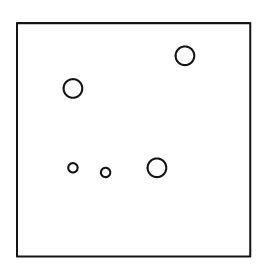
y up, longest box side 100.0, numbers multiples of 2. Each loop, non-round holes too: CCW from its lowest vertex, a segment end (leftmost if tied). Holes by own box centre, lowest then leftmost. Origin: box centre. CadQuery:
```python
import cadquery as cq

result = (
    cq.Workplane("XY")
    .moveTo(-50.0, -50.0)
    .lineTo(50.0, -50.0)
    .lineTo(50.0, 50.0)
    .lineTo(-50.0, 50.0)
    .close()
    .moveTo(-12.0, -14.0)
    .circle(2.0)
    .moveTo(-26.0, -12.0)
    .circle(2.0)
    .moveTo(10.0, -12.0)
    .circle(4.0)
    .moveTo(-26.0, 22.0)
    .circle(4.0)
    .moveTo(22.0, 36.0)
    .circle(4.0)
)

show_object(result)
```